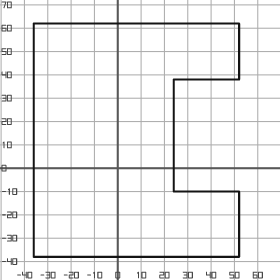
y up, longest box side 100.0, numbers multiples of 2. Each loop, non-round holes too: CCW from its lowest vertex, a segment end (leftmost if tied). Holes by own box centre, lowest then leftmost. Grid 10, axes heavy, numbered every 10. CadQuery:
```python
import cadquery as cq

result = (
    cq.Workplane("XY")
    .moveTo(-36.0, -38.0)
    .lineTo(52.0, -38.0)
    .lineTo(52.0, -10.0)
    .lineTo(24.0, -10.0)
    .lineTo(24.0, 38.0)
    .lineTo(52.0, 38.0)
    .lineTo(52.0, 62.0)
    .lineTo(-36.0, 62.0)
    .close()
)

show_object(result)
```